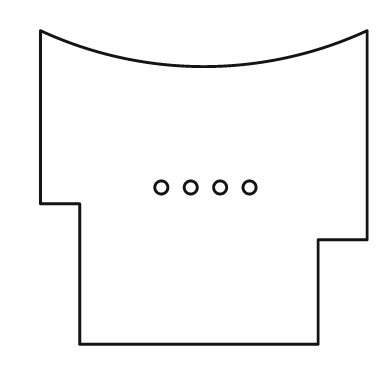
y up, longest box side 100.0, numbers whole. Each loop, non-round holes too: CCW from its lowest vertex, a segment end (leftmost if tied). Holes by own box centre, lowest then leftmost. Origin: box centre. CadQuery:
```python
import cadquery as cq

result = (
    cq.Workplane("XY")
    .moveTo(-38.0, -48.0)
    .lineTo(35.0, -48.0)
    .lineTo(35.0, -16.0)
    .lineTo(50.0, -16.0)
    .lineTo(50.0, 48.0)
    .threePointArc((0.0, 37.0), (-50.0, 48.0))
    .lineTo(-50.0, -5.0)
    .lineTo(-38.0, -5.0)
    .close()
    .moveTo(-13.0, 0.0)
    .circle(2.0)
    .moveTo(-4.0, 0.0)
    .circle(2.0)
    .moveTo(5.0, 0.0)
    .circle(2.0)
    .moveTo(14.0, 0.0)
    .circle(2.0)
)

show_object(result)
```